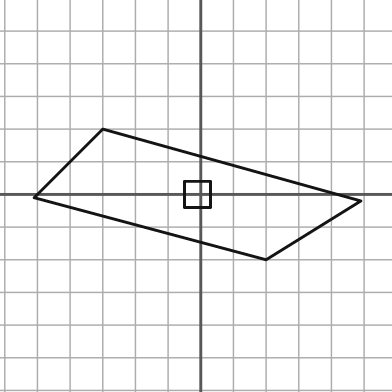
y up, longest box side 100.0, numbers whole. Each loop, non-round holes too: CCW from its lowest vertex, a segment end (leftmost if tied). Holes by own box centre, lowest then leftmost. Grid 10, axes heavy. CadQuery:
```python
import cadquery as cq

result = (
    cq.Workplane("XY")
    .moveTo(20.0, -20.0)
    .lineTo(49.0, -2.0)
    .lineTo(-30.0, 20.0)
    .lineTo(-51.0, -1.0)
    .close()
    .moveTo(-5.0, -4.0)
    .lineTo(3.0, -4.0)
    .lineTo(3.0, 4.0)
    .lineTo(-5.0, 4.0)
    .close()
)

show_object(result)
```